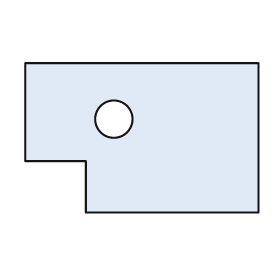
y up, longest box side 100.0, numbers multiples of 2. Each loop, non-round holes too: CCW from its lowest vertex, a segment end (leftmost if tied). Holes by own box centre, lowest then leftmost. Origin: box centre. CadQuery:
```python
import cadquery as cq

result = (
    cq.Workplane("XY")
    .moveTo(-24.0, -32.0)
    .lineTo(50.0, -32.0)
    .lineTo(50.0, 32.0)
    .lineTo(-50.0, 32.0)
    .lineTo(-50.0, -10.0)
    .lineTo(-24.0, -10.0)
    .close()
    .moveTo(-12.0, 8.0)
    .circle(8.0)
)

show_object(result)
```